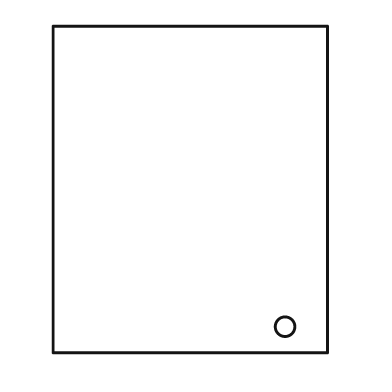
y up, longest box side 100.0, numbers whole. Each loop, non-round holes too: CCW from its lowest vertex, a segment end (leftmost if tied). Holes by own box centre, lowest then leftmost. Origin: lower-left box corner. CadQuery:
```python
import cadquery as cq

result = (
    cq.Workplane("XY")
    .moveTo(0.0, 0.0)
    .lineTo(84.0, 0.0)
    .lineTo(84.0, 100.0)
    .lineTo(0.0, 100.0)
    .close()
    .moveTo(71.0, 8.0)
    .circle(3.0)
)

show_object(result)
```